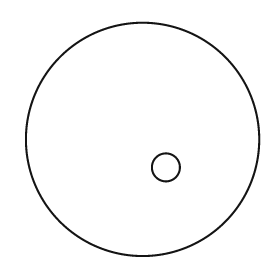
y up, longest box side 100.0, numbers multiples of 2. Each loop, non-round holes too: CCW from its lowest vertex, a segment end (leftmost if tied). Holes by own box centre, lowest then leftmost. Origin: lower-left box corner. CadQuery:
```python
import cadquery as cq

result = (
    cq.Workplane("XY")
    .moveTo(50.0, 50.0)
    .circle(50.0)
    .moveTo(60.0, 38.0)
    .circle(6.0)
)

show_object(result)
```